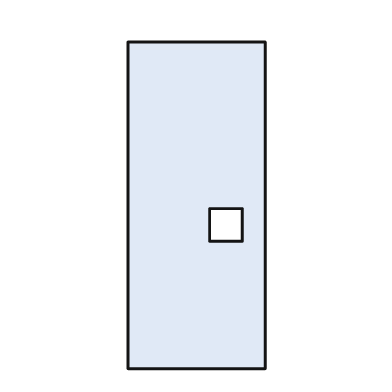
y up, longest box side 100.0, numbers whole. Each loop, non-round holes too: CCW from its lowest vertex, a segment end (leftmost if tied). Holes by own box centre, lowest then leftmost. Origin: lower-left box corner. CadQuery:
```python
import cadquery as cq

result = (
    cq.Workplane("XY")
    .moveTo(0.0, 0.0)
    .lineTo(42.0, 0.0)
    .lineTo(42.0, 100.0)
    .lineTo(0.0, 100.0)
    .close()
    .moveTo(25.0, 39.0)
    .lineTo(35.0, 39.0)
    .lineTo(35.0, 49.0)
    .lineTo(25.0, 49.0)
    .close()
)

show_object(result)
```